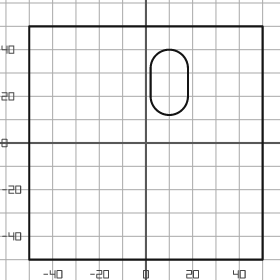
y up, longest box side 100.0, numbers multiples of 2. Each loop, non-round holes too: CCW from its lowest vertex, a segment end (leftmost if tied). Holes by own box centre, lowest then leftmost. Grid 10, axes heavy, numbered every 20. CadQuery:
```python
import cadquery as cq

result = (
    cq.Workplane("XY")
    .moveTo(-50.0, -50.0)
    .lineTo(50.0, -50.0)
    .lineTo(50.0, 50.0)
    .lineTo(-50.0, 50.0)
    .close()
    .moveTo(2.0, 20.0)
    .threePointArc((10.0, 12.0), (18.0, 20.0))
    .lineTo(18.0, 32.0)
    .threePointArc((10.0, 40.0), (2.0, 32.0))
    .close()
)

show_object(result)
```